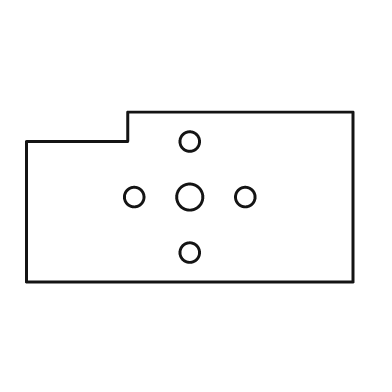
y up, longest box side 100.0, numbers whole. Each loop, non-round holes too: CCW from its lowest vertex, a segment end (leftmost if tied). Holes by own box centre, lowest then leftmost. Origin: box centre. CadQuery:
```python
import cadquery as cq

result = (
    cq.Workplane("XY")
    .moveTo(-50.0, -26.0)
    .lineTo(50.0, -26.0)
    .lineTo(50.0, 26.0)
    .lineTo(-19.0, 26.0)
    .lineTo(-19.0, 17.0)
    .lineTo(-50.0, 17.0)
    .close()
    .moveTo(0.0, -17.0)
    .circle(3.0)
    .moveTo(-17.0, 0.0)
    .circle(3.0)
    .moveTo(0.0, 0.0)
    .circle(4.0)
    .moveTo(17.0, 0.0)
    .circle(3.0)
    .moveTo(0.0, 17.0)
    .circle(3.0)
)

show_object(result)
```